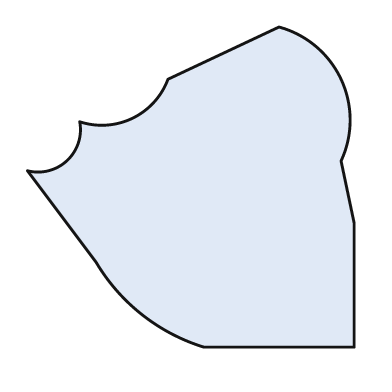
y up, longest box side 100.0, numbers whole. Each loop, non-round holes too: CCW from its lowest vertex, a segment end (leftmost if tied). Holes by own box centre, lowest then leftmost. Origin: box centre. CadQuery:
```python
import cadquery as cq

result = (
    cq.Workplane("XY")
    .moveTo(4.0, -49.0)
    .lineTo(50.0, -49.0)
    .lineTo(50.0, -11.0)
    .lineTo(46.0, 8.0)
    .threePointArc((46.0, 33.0), (27.0, 49.0))
    .lineTo(-7.0, 33.0)
    .threePointArc((-18.0, 21.0), (-34.0, 20.0))
    .threePointArc((-38.0, 8.0), (-50.0, 5.0))
    .lineTo(-29.0, -23.0)
    .threePointArc((-15.0, -39.0), (4.0, -49.0))
    .close()
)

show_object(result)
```